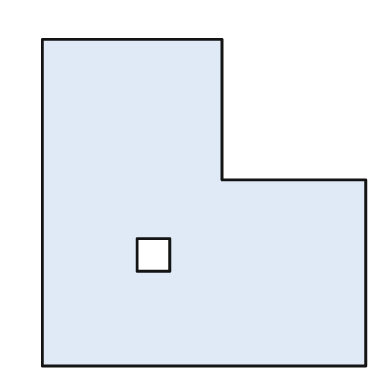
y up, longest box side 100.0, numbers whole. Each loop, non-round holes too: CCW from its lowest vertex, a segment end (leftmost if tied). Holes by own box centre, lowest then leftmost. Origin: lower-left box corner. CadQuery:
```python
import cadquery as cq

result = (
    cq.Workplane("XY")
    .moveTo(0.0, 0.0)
    .lineTo(99.0, 0.0)
    .lineTo(99.0, 57.0)
    .lineTo(55.0, 57.0)
    .lineTo(55.0, 100.0)
    .lineTo(0.0, 100.0)
    .close()
    .moveTo(29.0, 29.0)
    .lineTo(39.0, 29.0)
    .lineTo(39.0, 39.0)
    .lineTo(29.0, 39.0)
    .close()
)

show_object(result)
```